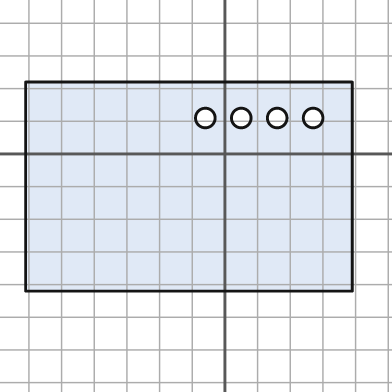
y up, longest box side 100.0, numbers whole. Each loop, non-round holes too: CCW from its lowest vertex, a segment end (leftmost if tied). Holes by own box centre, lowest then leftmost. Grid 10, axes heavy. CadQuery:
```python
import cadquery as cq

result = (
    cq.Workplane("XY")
    .moveTo(-61.0, -42.0)
    .lineTo(39.0, -42.0)
    .lineTo(39.0, 22.0)
    .lineTo(-61.0, 22.0)
    .close()
    .moveTo(-6.0, 11.0)
    .circle(3.0)
    .moveTo(5.0, 11.0)
    .circle(3.0)
    .moveTo(16.0, 11.0)
    .circle(3.0)
    .moveTo(27.0, 11.0)
    .circle(3.0)
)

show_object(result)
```